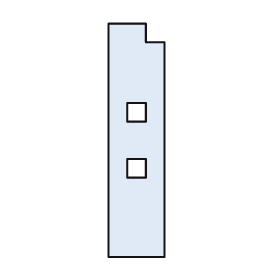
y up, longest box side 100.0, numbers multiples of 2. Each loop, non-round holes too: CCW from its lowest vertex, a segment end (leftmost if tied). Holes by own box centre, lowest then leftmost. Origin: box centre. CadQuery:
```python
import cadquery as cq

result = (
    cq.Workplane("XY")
    .moveTo(-12.0, -50.0)
    .lineTo(12.0, -50.0)
    .lineTo(12.0, 42.0)
    .lineTo(4.0, 42.0)
    .lineTo(4.0, 50.0)
    .lineTo(-12.0, 50.0)
    .close()
    .moveTo(-4.0, -16.0)
    .lineTo(4.0, -16.0)
    .lineTo(4.0, -8.0)
    .lineTo(-4.0, -8.0)
    .close()
    .moveTo(-4.0, 8.0)
    .lineTo(4.0, 8.0)
    .lineTo(4.0, 16.0)
    .lineTo(-4.0, 16.0)
    .close()
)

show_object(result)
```